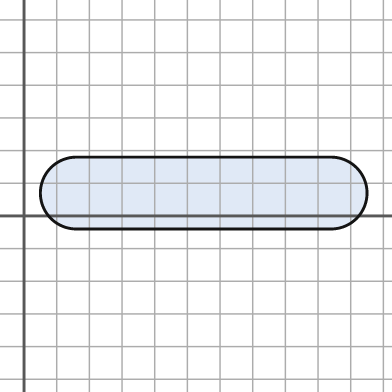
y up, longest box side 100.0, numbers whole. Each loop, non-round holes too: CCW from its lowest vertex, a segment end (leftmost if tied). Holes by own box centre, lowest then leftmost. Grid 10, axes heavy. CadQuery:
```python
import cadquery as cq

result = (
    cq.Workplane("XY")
    .moveTo(16.0, -4.0)
    .lineTo(94.0, -4.0)
    .threePointArc((105.0, 7.0), (94.0, 18.0))
    .lineTo(16.0, 18.0)
    .threePointArc((5.0, 7.0), (16.0, -4.0))
    .close()
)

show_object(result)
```